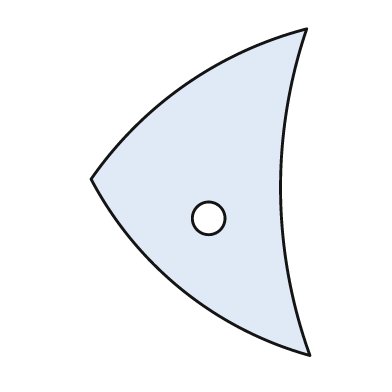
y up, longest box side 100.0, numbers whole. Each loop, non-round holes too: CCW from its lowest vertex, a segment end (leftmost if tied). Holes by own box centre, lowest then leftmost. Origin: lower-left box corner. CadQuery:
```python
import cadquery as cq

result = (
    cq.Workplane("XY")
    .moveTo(67.0, 0.0)
    .threePointArc((58.0, 50.0), (66.0, 100.0))
    .threePointArc((29.0, 83.0), (0.0, 54.0))
    .threePointArc((28.0, 20.0), (67.0, 0.0))
    .close()
    .moveTo(36.0, 42.0)
    .circle(5.0)
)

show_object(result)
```